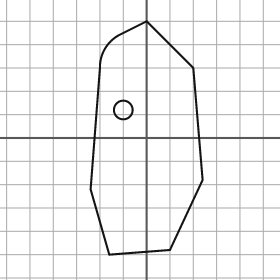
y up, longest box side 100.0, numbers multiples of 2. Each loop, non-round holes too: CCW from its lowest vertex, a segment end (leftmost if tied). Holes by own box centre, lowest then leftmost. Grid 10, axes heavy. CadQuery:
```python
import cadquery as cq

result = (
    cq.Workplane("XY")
    .moveTo(-16.0, -50.0)
    .lineTo(10.0, -48.0)
    .lineTo(24.0, -18.0)
    .lineTo(20.0, 30.0)
    .lineTo(0.0, 50.0)
    .lineTo(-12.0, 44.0)
    .threePointArc((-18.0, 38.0), (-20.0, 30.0))
    .lineTo(-24.0, -22.0)
    .close()
    .moveTo(-10.0, 12.0)
    .circle(4.0)
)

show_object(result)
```